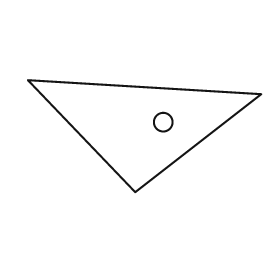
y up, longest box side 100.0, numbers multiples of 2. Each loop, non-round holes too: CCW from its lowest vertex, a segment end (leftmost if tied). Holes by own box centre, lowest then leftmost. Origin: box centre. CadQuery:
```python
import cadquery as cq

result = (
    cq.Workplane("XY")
    .moveTo(-4.0, -24.0)
    .lineTo(50.0, 18.0)
    .lineTo(-50.0, 24.0)
    .close()
    .moveTo(8.0, 6.0)
    .circle(4.0)
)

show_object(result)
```